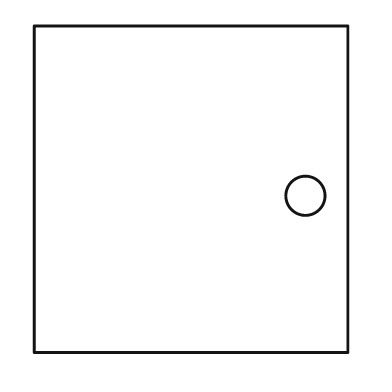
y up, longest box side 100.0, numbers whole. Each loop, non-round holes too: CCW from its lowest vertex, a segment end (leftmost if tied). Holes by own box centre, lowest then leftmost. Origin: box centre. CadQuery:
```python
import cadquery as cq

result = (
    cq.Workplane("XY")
    .moveTo(-48.0, -50.0)
    .lineTo(48.0, -50.0)
    .lineTo(48.0, 50.0)
    .lineTo(-48.0, 50.0)
    .close()
    .moveTo(35.0, -2.0)
    .circle(6.0)
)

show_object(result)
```